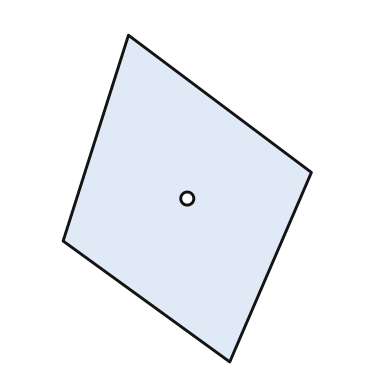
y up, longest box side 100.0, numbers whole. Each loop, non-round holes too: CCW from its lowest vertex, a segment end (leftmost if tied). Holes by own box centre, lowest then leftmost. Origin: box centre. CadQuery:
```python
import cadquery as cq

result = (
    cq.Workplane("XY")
    .moveTo(13.0, -50.0)
    .lineTo(38.0, 8.0)
    .lineTo(-18.0, 50.0)
    .lineTo(-38.0, -13.0)
    .close()
    .moveTo(0.0, 0.0)
    .circle(2.0)
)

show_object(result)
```